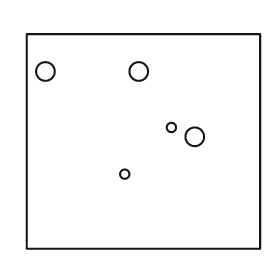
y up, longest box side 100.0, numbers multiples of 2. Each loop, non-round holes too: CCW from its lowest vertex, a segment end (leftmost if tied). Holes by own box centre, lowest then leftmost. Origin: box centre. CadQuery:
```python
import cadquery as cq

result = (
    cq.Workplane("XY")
    .moveTo(-50.0, -46.0)
    .lineTo(50.0, -46.0)
    .lineTo(50.0, 46.0)
    .lineTo(-50.0, 46.0)
    .close()
    .moveTo(-8.0, -14.0)
    .circle(2.0)
    .moveTo(22.0, 2.0)
    .circle(4.0)
    .moveTo(12.0, 6.0)
    .circle(2.0)
    .moveTo(-42.0, 30.0)
    .circle(4.0)
    .moveTo(-2.0, 30.0)
    .circle(4.0)
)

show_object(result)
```